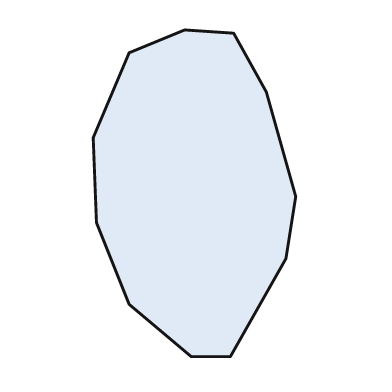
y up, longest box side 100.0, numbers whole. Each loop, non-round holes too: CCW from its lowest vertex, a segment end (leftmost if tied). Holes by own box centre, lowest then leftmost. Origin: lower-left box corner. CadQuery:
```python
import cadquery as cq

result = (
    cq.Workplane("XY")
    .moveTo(30.0, 0.0)
    .lineTo(42.0, 0.0)
    .lineTo(59.0, 30.0)
    .lineTo(62.0, 49.0)
    .lineTo(53.0, 81.0)
    .lineTo(43.0, 99.0)
    .lineTo(28.0, 100.0)
    .lineTo(11.0, 93.0)
    .lineTo(0.0, 67.0)
    .lineTo(1.0, 41.0)
    .lineTo(11.0, 16.0)
    .close()
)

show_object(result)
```